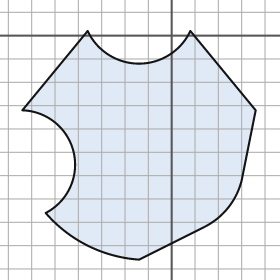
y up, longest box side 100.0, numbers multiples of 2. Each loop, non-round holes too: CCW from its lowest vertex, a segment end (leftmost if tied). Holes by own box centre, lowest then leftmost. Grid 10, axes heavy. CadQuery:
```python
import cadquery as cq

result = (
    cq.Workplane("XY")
    .moveTo(-14.0, -96.0)
    .lineTo(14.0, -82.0)
    .threePointArc((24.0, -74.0), (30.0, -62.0))
    .lineTo(36.0, -32.0)
    .lineTo(8.0, 2.0)
    .threePointArc((-14.0, -12.0), (-36.0, 2.0))
    .lineTo(-64.0, -32.0)
    .threePointArc((-42.0, -50.0), (-54.0, -76.0))
    .threePointArc((-36.0, -90.0), (-14.0, -96.0))
    .close()
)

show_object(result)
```